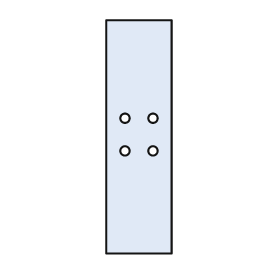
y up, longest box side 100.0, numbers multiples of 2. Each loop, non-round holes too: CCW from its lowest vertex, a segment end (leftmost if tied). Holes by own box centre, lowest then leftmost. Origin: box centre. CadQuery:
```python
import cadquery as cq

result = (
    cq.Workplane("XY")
    .moveTo(-14.0, -50.0)
    .lineTo(14.0, -50.0)
    .lineTo(14.0, 50.0)
    .lineTo(-14.0, 50.0)
    .close()
    .moveTo(-6.0, -6.0)
    .circle(2.0)
    .moveTo(6.0, -6.0)
    .circle(2.0)
    .moveTo(-6.0, 8.0)
    .circle(2.0)
    .moveTo(6.0, 8.0)
    .circle(2.0)
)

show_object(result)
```